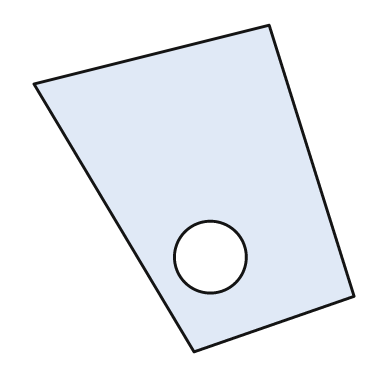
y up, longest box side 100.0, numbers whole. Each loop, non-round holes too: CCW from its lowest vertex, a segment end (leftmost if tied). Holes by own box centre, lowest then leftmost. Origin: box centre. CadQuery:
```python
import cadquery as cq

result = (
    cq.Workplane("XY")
    .moveTo(0.0, -50.0)
    .lineTo(49.0, -33.0)
    .lineTo(23.0, 50.0)
    .lineTo(-49.0, 32.0)
    .close()
    .moveTo(5.0, -21.0)
    .circle(11.0)
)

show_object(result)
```